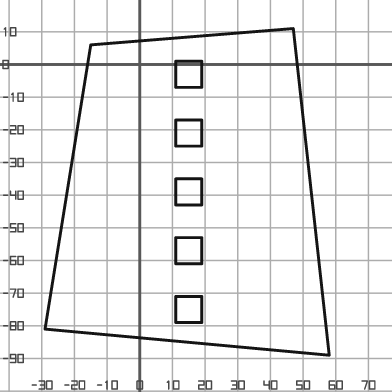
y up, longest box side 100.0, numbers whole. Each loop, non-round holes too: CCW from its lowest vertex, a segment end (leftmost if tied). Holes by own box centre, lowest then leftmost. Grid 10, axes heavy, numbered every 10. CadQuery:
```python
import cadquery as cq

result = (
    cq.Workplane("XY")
    .moveTo(58.0, -89.0)
    .lineTo(47.0, 11.0)
    .lineTo(-15.0, 6.0)
    .lineTo(-29.0, -81.0)
    .close()
    .moveTo(11.0, -79.0)
    .lineTo(19.0, -79.0)
    .lineTo(19.0, -71.0)
    .lineTo(11.0, -71.0)
    .close()
    .moveTo(11.0, -61.0)
    .lineTo(19.0, -61.0)
    .lineTo(19.0, -53.0)
    .lineTo(11.0, -53.0)
    .close()
    .moveTo(11.0, -43.0)
    .lineTo(19.0, -43.0)
    .lineTo(19.0, -35.0)
    .lineTo(11.0, -35.0)
    .close()
    .moveTo(11.0, -25.0)
    .lineTo(19.0, -25.0)
    .lineTo(19.0, -17.0)
    .lineTo(11.0, -17.0)
    .close()
    .moveTo(11.0, -7.0)
    .lineTo(19.0, -7.0)
    .lineTo(19.0, 1.0)
    .lineTo(11.0, 1.0)
    .close()
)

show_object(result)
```